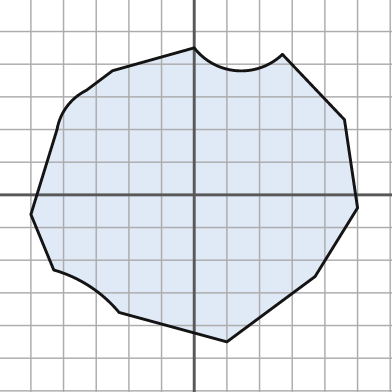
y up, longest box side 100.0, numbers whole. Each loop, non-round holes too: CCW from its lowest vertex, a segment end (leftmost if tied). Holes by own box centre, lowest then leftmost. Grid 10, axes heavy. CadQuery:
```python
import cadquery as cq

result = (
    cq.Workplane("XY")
    .moveTo(10.0, -45.0)
    .lineTo(37.0, -25.0)
    .lineTo(50.0, -4.0)
    .lineTo(46.0, 23.0)
    .lineTo(27.0, 43.0)
    .threePointArc((13.0, 38.0), (0.0, 45.0))
    .lineTo(-25.0, 38.0)
    .lineTo(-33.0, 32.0)
    .threePointArc((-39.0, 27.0), (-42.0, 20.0))
    .lineTo(-50.0, -6.0)
    .lineTo(-43.0, -23.0)
    .threePointArc((-32.0, -28.0), (-23.0, -36.0))
    .close()
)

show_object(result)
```